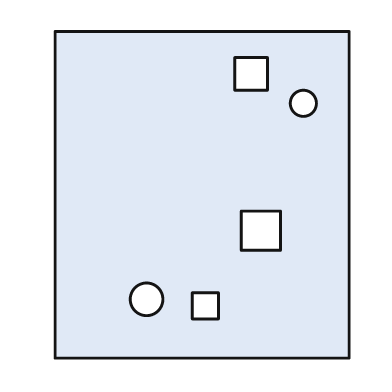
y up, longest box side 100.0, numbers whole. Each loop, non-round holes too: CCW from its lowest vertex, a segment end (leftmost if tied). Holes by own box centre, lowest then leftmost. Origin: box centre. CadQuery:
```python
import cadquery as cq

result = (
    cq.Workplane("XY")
    .moveTo(-45.0, -50.0)
    .lineTo(45.0, -50.0)
    .lineTo(45.0, 50.0)
    .lineTo(-45.0, 50.0)
    .close()
    .moveTo(-3.0, -38.0)
    .lineTo(5.0, -38.0)
    .lineTo(5.0, -30.0)
    .lineTo(-3.0, -30.0)
    .close()
    .moveTo(-17.0, -32.0)
    .circle(5.0)
    .moveTo(12.0, -17.0)
    .lineTo(24.0, -17.0)
    .lineTo(24.0, -5.0)
    .lineTo(12.0, -5.0)
    .close()
    .moveTo(31.0, 28.0)
    .circle(4.0)
    .moveTo(10.0, 32.0)
    .lineTo(20.0, 32.0)
    .lineTo(20.0, 42.0)
    .lineTo(10.0, 42.0)
    .close()
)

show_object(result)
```